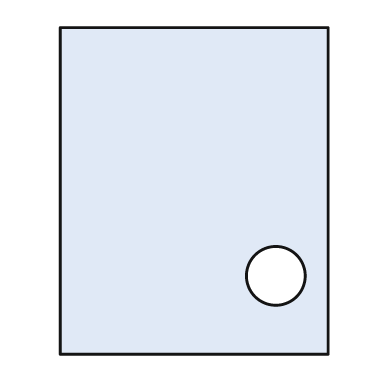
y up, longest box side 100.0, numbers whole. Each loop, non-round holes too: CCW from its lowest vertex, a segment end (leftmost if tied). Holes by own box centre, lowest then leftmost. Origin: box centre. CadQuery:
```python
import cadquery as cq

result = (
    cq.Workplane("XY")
    .moveTo(-41.0, -50.0)
    .lineTo(41.0, -50.0)
    .lineTo(41.0, 50.0)
    .lineTo(-41.0, 50.0)
    .close()
    .moveTo(25.0, -26.0)
    .circle(9.0)
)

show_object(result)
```